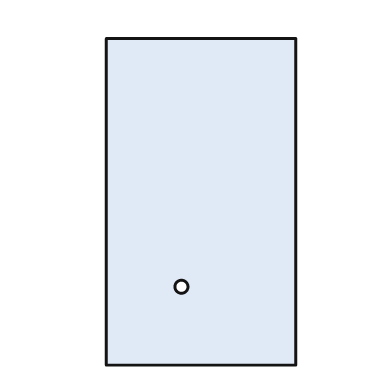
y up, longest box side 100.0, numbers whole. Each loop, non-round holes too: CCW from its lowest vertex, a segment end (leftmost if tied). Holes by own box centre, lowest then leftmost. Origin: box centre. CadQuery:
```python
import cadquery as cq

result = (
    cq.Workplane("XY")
    .moveTo(-29.0, -50.0)
    .lineTo(29.0, -50.0)
    .lineTo(29.0, 50.0)
    .lineTo(-29.0, 50.0)
    .close()
    .moveTo(-6.0, -26.0)
    .circle(2.0)
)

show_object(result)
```